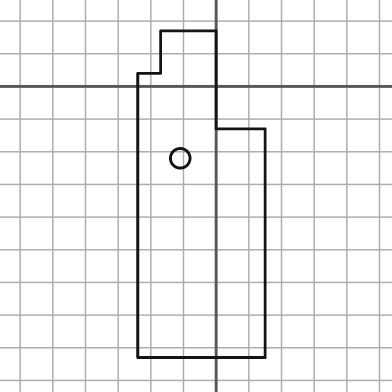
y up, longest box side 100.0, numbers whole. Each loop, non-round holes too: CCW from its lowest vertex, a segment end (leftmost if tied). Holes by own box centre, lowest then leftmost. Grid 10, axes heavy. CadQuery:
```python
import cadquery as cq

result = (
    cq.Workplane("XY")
    .moveTo(-24.0, -83.0)
    .lineTo(15.0, -83.0)
    .lineTo(15.0, -13.0)
    .lineTo(0.0, -13.0)
    .lineTo(0.0, 17.0)
    .lineTo(-17.0, 17.0)
    .lineTo(-17.0, 4.0)
    .lineTo(-24.0, 4.0)
    .close()
    .moveTo(-11.0, -22.0)
    .circle(3.0)
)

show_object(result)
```